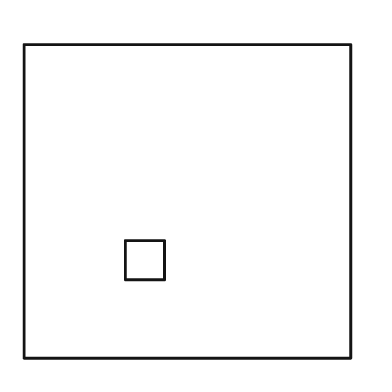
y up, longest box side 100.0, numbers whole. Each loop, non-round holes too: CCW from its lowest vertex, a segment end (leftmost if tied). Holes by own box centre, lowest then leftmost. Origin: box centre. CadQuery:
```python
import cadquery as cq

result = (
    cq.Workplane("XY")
    .moveTo(-50.0, -48.0)
    .lineTo(50.0, -48.0)
    .lineTo(50.0, 48.0)
    .lineTo(-50.0, 48.0)
    .close()
    .moveTo(-19.0, -24.0)
    .lineTo(-7.0, -24.0)
    .lineTo(-7.0, -12.0)
    .lineTo(-19.0, -12.0)
    .close()
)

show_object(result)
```